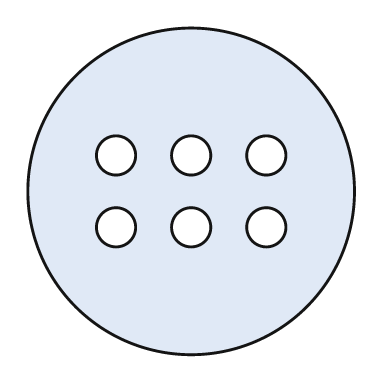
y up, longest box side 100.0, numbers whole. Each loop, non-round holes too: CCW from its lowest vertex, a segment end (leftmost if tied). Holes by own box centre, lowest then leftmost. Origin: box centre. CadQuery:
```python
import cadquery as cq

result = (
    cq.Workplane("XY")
    .moveTo(0.0, 0.0)
    .circle(50.0)
    .moveTo(-23.0, -11.0)
    .circle(6.0)
    .moveTo(0.0, -11.0)
    .circle(6.0)
    .moveTo(23.0, -11.0)
    .circle(6.0)
    .moveTo(-23.0, 11.0)
    .circle(6.0)
    .moveTo(0.0, 11.0)
    .circle(6.0)
    .moveTo(23.0, 11.0)
    .circle(6.0)
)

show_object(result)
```